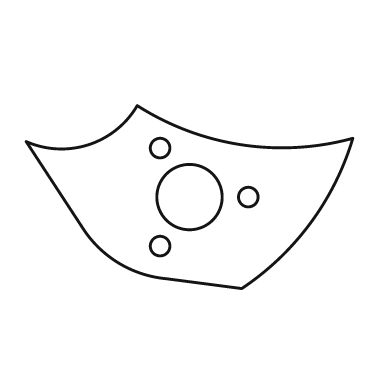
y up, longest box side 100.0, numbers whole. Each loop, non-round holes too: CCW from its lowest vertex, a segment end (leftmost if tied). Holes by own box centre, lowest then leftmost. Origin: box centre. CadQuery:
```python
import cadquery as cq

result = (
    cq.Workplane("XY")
    .moveTo(16.0, -28.0)
    .threePointArc((37.0, -8.0), (50.0, 18.0))
    .threePointArc((16.0, 16.0), (-16.0, 28.0))
    .threePointArc((-31.0, 16.0), (-50.0, 17.0))
    .lineTo(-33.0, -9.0)
    .threePointArc((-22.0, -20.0), (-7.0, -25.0))
    .close()
    .moveTo(-9.0, -15.0)
    .circle(3.0)
    .moveTo(0.0, 0.0)
    .circle(10.0)
    .moveTo(18.0, 0.0)
    .circle(3.0)
    .moveTo(-9.0, 15.0)
    .circle(3.0)
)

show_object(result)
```